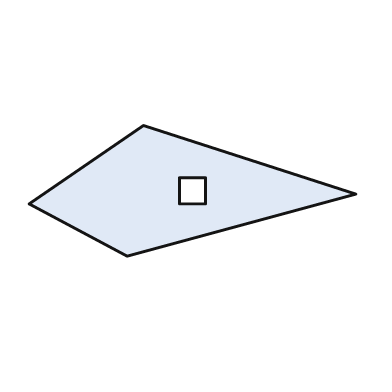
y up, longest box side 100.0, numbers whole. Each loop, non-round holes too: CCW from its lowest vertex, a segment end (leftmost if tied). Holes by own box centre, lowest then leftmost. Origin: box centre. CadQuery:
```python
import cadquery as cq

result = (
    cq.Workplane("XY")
    .moveTo(-20.0, -20.0)
    .lineTo(50.0, -1.0)
    .lineTo(-15.0, 20.0)
    .lineTo(-50.0, -4.0)
    .close()
    .moveTo(-4.0, -4.0)
    .lineTo(4.0, -4.0)
    .lineTo(4.0, 4.0)
    .lineTo(-4.0, 4.0)
    .close()
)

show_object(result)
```